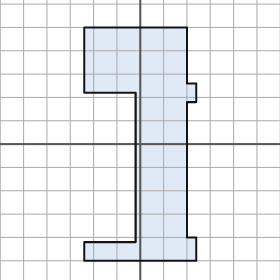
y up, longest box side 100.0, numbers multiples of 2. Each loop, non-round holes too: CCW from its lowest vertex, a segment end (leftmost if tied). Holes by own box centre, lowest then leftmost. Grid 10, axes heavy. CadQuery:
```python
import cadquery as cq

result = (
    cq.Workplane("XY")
    .moveTo(-24.0, -50.0)
    .lineTo(24.0, -50.0)
    .lineTo(24.0, -40.0)
    .lineTo(20.0, -40.0)
    .lineTo(20.0, 18.0)
    .lineTo(24.0, 18.0)
    .lineTo(24.0, 26.0)
    .lineTo(20.0, 26.0)
    .lineTo(20.0, 50.0)
    .lineTo(-24.0, 50.0)
    .lineTo(-24.0, 22.0)
    .lineTo(-2.0, 22.0)
    .lineTo(-2.0, -42.0)
    .lineTo(-24.0, -42.0)
    .close()
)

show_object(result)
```